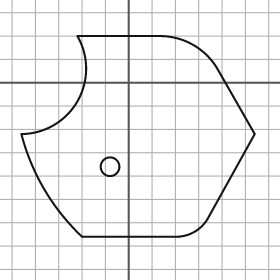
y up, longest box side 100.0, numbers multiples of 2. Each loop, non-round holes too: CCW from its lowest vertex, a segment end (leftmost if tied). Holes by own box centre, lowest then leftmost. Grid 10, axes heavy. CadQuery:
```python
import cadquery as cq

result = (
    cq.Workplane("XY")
    .moveTo(-20.0, -66.0)
    .lineTo(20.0, -66.0)
    .threePointArc((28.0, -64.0), (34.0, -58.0))
    .lineTo(54.0, -22.0)
    .lineTo(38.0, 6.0)
    .threePointArc((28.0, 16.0), (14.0, 20.0))
    .lineTo(-22.0, 20.0)
    .threePointArc((-22.0, -8.0), (-46.0, -22.0))
    .threePointArc((-36.0, -46.0), (-20.0, -66.0))
    .close()
    .moveTo(-8.0, -36.0)
    .circle(4.0)
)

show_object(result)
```